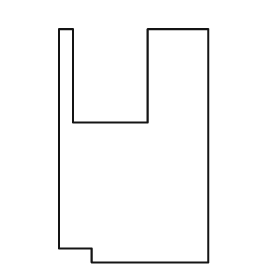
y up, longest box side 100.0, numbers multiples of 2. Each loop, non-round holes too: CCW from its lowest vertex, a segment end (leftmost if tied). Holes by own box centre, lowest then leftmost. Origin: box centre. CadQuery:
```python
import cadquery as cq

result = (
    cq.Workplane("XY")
    .moveTo(-18.0, -50.0)
    .lineTo(32.0, -50.0)
    .lineTo(32.0, 50.0)
    .lineTo(6.0, 50.0)
    .lineTo(6.0, 10.0)
    .lineTo(-26.0, 10.0)
    .lineTo(-26.0, 50.0)
    .lineTo(-32.0, 50.0)
    .lineTo(-32.0, -44.0)
    .lineTo(-18.0, -44.0)
    .close()
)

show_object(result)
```